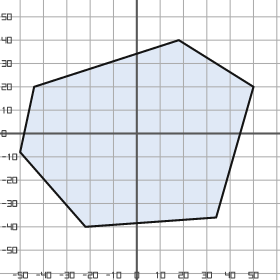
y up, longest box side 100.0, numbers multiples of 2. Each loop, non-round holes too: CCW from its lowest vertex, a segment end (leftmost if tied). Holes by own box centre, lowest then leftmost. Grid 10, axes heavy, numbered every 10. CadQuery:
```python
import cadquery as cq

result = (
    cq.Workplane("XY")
    .moveTo(-22.0, -40.0)
    .lineTo(34.0, -36.0)
    .lineTo(50.0, 20.0)
    .lineTo(18.0, 40.0)
    .lineTo(-44.0, 20.0)
    .lineTo(-50.0, -8.0)
    .close()
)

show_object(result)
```